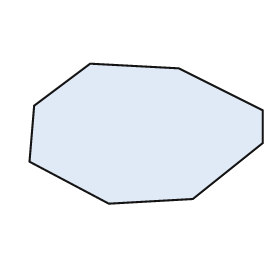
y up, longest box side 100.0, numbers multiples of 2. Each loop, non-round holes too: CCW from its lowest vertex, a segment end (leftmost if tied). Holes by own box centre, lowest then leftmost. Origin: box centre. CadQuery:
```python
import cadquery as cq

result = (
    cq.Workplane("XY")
    .moveTo(-16.0, -30.0)
    .lineTo(20.0, -28.0)
    .lineTo(50.0, -4.0)
    .lineTo(50.0, 10.0)
    .lineTo(14.0, 28.0)
    .lineTo(-24.0, 30.0)
    .lineTo(-48.0, 12.0)
    .lineTo(-50.0, -12.0)
    .close()
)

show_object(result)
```